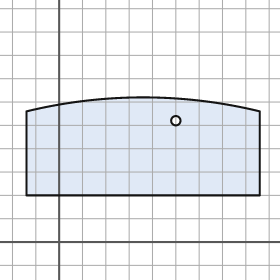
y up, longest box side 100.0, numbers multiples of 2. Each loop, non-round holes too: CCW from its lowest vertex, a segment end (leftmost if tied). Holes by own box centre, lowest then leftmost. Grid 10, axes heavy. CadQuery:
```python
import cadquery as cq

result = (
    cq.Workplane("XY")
    .moveTo(-14.0, 20.0)
    .lineTo(86.0, 20.0)
    .lineTo(86.0, 56.0)
    .threePointArc((36.0, 62.0), (-14.0, 56.0))
    .close()
    .moveTo(50.0, 52.0)
    .circle(2.0)
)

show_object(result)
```